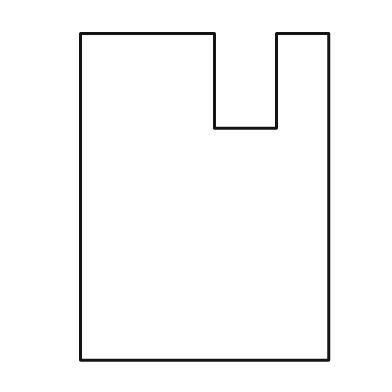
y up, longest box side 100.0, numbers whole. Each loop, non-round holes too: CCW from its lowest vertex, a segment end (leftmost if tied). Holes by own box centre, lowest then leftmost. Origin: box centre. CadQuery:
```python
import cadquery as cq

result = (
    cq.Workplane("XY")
    .moveTo(-38.0, -50.0)
    .lineTo(38.0, -50.0)
    .lineTo(38.0, 50.0)
    .lineTo(22.0, 50.0)
    .lineTo(22.0, 21.0)
    .lineTo(3.0, 21.0)
    .lineTo(3.0, 50.0)
    .lineTo(-38.0, 50.0)
    .close()
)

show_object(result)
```